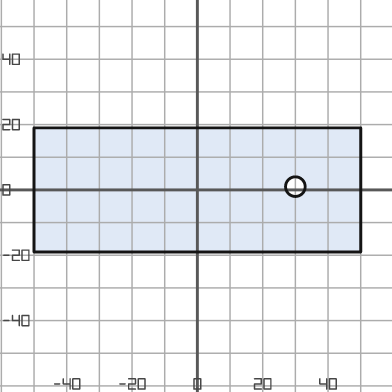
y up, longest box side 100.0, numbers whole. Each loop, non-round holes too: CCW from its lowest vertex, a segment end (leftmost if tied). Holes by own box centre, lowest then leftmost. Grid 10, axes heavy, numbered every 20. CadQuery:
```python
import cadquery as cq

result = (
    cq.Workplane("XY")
    .moveTo(-50.0, -19.0)
    .lineTo(50.0, -19.0)
    .lineTo(50.0, 19.0)
    .lineTo(-50.0, 19.0)
    .close()
    .moveTo(30.0, 1.0)
    .circle(3.0)
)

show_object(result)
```